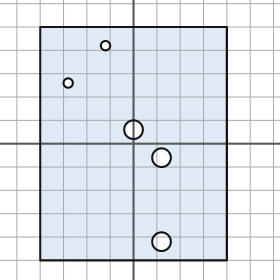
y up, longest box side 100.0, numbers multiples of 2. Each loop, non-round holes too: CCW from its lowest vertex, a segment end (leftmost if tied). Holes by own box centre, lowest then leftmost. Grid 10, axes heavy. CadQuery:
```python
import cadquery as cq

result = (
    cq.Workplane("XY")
    .moveTo(-40.0, -50.0)
    .lineTo(40.0, -50.0)
    .lineTo(40.0, 50.0)
    .lineTo(-40.0, 50.0)
    .close()
    .moveTo(12.0, -42.0)
    .circle(4.0)
    .moveTo(12.0, -6.0)
    .circle(4.0)
    .moveTo(0.0, 6.0)
    .circle(4.0)
    .moveTo(-28.0, 26.0)
    .circle(2.0)
    .moveTo(-12.0, 42.0)
    .circle(2.0)
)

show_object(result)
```